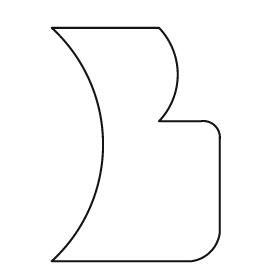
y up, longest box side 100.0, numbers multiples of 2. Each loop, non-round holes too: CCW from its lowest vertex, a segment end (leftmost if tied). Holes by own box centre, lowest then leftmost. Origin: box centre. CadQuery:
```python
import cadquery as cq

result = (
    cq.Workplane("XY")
    .moveTo(-36.0, -50.0)
    .lineTo(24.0, -50.0)
    .threePointArc((32.0, -46.0), (36.0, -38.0))
    .lineTo(36.0, 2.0)
    .threePointArc((34.0, 8.0), (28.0, 10.0))
    .lineTo(10.0, 10.0)
    .threePointArc((18.0, 30.0), (10.0, 50.0))
    .lineTo(-36.0, 50.0)
    .threePointArc((-14.0, 0.0), (-36.0, -50.0))
    .close()
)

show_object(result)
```